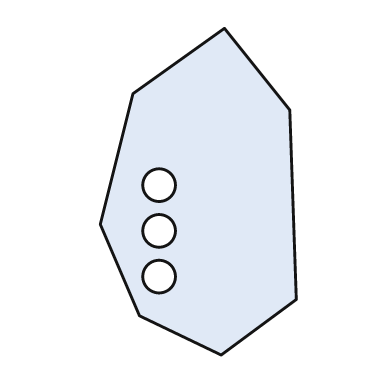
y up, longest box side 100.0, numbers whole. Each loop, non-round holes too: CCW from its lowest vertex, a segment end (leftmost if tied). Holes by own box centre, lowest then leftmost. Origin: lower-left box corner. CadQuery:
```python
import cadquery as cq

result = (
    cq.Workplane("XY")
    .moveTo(37.0, 0.0)
    .lineTo(60.0, 17.0)
    .lineTo(58.0, 75.0)
    .lineTo(38.0, 100.0)
    .lineTo(10.0, 80.0)
    .lineTo(0.0, 40.0)
    .lineTo(12.0, 12.0)
    .close()
    .moveTo(18.0, 24.0)
    .circle(5.0)
    .moveTo(18.0, 38.0)
    .circle(5.0)
    .moveTo(18.0, 52.0)
    .circle(5.0)
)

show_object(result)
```